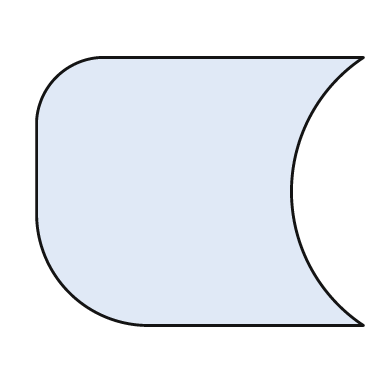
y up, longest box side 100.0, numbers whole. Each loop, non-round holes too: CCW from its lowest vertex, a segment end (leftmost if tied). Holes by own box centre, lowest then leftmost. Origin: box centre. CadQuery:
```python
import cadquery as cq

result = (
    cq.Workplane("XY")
    .moveTo(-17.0, -41.0)
    .lineTo(50.0, -41.0)
    .threePointArc((28.0, 0.0), (50.0, 41.0))
    .lineTo(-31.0, 41.0)
    .threePointArc((-44.0, 35.0), (-50.0, 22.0))
    .lineTo(-50.0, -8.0)
    .threePointArc((-40.0, -31.0), (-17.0, -41.0))
    .close()
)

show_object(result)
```